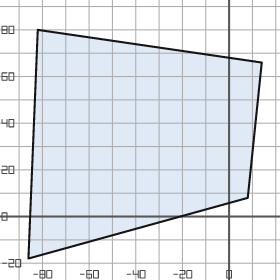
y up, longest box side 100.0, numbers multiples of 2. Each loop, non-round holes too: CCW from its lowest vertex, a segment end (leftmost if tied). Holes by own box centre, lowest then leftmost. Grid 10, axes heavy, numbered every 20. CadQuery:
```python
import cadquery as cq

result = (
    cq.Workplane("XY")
    .moveTo(-86.0, -18.0)
    .lineTo(8.0, 8.0)
    .lineTo(14.0, 66.0)
    .lineTo(-82.0, 80.0)
    .close()
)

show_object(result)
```